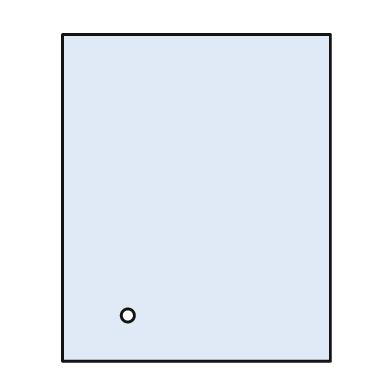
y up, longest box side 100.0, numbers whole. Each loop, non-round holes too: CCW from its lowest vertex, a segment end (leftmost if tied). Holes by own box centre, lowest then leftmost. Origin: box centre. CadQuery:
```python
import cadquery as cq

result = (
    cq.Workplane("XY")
    .moveTo(-41.0, -50.0)
    .lineTo(41.0, -50.0)
    .lineTo(41.0, 50.0)
    .lineTo(-41.0, 50.0)
    .close()
    .moveTo(-21.0, -36.0)
    .circle(2.0)
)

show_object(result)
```